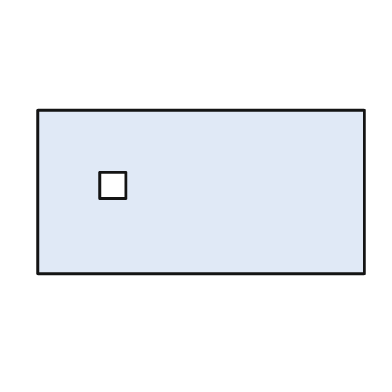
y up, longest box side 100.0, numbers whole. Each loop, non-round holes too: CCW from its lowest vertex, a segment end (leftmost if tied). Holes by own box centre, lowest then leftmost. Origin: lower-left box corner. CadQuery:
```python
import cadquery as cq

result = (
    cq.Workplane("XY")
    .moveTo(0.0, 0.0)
    .lineTo(100.0, 0.0)
    .lineTo(100.0, 50.0)
    .lineTo(0.0, 50.0)
    .close()
    .moveTo(19.0, 23.0)
    .lineTo(27.0, 23.0)
    .lineTo(27.0, 31.0)
    .lineTo(19.0, 31.0)
    .close()
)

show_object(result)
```